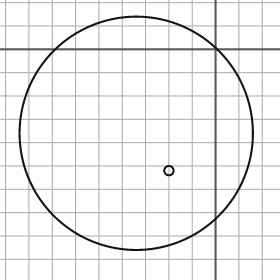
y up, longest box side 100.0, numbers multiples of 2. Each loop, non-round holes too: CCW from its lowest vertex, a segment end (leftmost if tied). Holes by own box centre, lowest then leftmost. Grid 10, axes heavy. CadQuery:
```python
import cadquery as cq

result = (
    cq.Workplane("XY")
    .moveTo(-34.0, -36.0)
    .circle(50.0)
    .moveTo(-20.0, -52.0)
    .circle(2.0)
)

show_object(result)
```